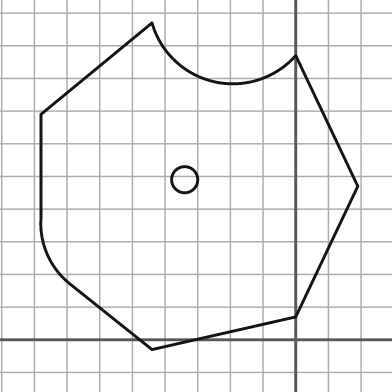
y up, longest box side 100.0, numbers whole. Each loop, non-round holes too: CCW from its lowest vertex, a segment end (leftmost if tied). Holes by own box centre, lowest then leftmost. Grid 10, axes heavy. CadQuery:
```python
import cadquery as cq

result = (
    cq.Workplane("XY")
    .moveTo(-44.0, -3.0)
    .lineTo(0.0, 7.0)
    .lineTo(19.0, 47.0)
    .lineTo(0.0, 87.0)
    .threePointArc((-25.0, 79.0), (-44.0, 97.0))
    .lineTo(-78.0, 69.0)
    .lineTo(-78.0, 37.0)
    .threePointArc((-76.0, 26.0), (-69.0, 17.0))
    .close()
    .moveTo(-34.0, 49.0)
    .circle(4.0)
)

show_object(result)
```